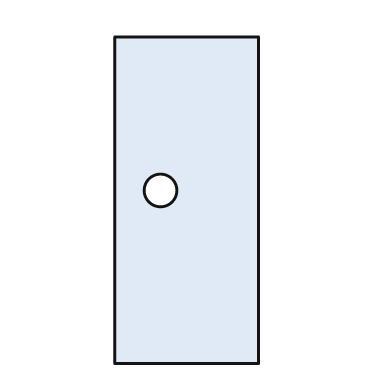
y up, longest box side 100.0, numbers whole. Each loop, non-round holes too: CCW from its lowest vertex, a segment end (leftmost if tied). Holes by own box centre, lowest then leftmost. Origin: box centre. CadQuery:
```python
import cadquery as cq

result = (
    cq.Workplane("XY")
    .moveTo(-22.0, -50.0)
    .lineTo(22.0, -50.0)
    .lineTo(22.0, 50.0)
    .lineTo(-22.0, 50.0)
    .close()
    .moveTo(-8.0, 3.0)
    .circle(5.0)
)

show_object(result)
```